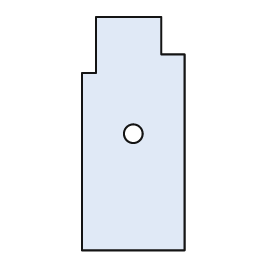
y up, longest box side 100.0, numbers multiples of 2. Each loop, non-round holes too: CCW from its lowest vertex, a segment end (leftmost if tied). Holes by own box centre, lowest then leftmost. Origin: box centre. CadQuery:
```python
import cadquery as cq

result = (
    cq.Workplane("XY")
    .moveTo(-22.0, -50.0)
    .lineTo(22.0, -50.0)
    .lineTo(22.0, 34.0)
    .lineTo(12.0, 34.0)
    .lineTo(12.0, 50.0)
    .lineTo(-16.0, 50.0)
    .lineTo(-16.0, 26.0)
    .lineTo(-22.0, 26.0)
    .close()
    .moveTo(0.0, 0.0)
    .circle(4.0)
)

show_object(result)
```